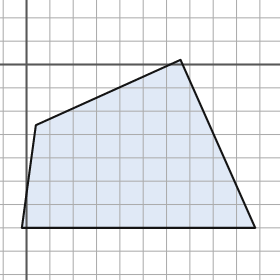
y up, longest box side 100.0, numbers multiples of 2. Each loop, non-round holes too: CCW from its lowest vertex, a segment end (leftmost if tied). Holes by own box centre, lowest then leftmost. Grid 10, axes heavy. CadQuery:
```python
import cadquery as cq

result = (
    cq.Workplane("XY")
    .moveTo(-2.0, -70.0)
    .lineTo(98.0, -70.0)
    .lineTo(66.0, 2.0)
    .lineTo(4.0, -26.0)
    .close()
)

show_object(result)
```